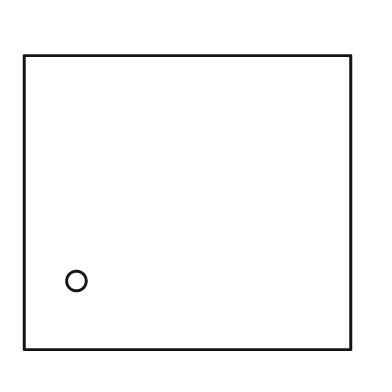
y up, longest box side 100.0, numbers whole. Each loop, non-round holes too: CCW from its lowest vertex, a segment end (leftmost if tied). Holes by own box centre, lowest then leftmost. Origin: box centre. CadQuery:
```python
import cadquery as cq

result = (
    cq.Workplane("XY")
    .moveTo(-50.0, -45.0)
    .lineTo(50.0, -45.0)
    .lineTo(50.0, 45.0)
    .lineTo(-50.0, 45.0)
    .close()
    .moveTo(-34.0, -24.0)
    .circle(3.0)
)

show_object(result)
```